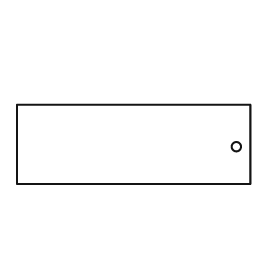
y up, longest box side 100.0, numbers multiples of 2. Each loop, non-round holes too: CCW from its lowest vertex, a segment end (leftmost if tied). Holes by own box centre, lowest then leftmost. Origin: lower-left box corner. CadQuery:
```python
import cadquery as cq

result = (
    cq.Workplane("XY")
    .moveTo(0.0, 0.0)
    .lineTo(100.0, 0.0)
    .lineTo(100.0, 34.0)
    .lineTo(0.0, 34.0)
    .close()
    .moveTo(94.0, 16.0)
    .circle(2.0)
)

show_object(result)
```